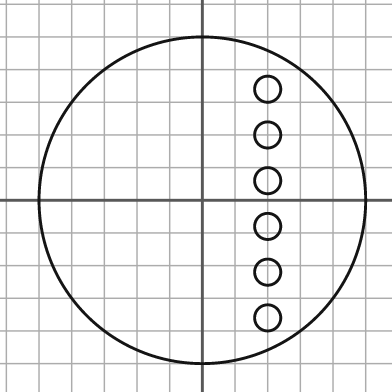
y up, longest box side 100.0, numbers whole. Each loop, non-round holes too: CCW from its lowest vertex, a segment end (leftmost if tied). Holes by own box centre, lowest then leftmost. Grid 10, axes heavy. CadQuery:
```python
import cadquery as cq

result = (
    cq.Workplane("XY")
    .moveTo(0.0, 0.0)
    .circle(50.0)
    .moveTo(20.0, -36.0)
    .circle(4.0)
    .moveTo(20.0, -22.0)
    .circle(4.0)
    .moveTo(20.0, -8.0)
    .circle(4.0)
    .moveTo(20.0, 6.0)
    .circle(4.0)
    .moveTo(20.0, 20.0)
    .circle(4.0)
    .moveTo(20.0, 34.0)
    .circle(4.0)
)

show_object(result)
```